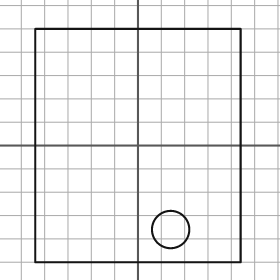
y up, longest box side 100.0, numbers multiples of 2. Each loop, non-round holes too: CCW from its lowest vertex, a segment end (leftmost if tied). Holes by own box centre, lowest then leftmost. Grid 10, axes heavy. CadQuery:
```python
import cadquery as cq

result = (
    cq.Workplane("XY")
    .moveTo(-44.0, -50.0)
    .lineTo(44.0, -50.0)
    .lineTo(44.0, 50.0)
    .lineTo(-44.0, 50.0)
    .close()
    .moveTo(14.0, -36.0)
    .circle(8.0)
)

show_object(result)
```